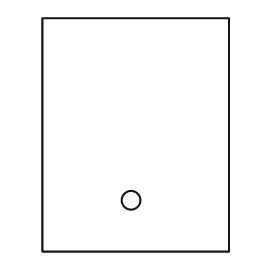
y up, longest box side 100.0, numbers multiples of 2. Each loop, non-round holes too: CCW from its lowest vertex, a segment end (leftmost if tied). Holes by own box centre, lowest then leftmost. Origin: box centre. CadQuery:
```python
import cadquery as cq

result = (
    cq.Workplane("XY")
    .moveTo(-40.0, -50.0)
    .lineTo(40.0, -50.0)
    .lineTo(40.0, 50.0)
    .lineTo(-40.0, 50.0)
    .close()
    .moveTo(-2.0, -28.0)
    .circle(4.0)
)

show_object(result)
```